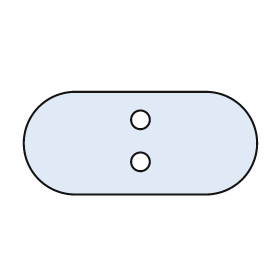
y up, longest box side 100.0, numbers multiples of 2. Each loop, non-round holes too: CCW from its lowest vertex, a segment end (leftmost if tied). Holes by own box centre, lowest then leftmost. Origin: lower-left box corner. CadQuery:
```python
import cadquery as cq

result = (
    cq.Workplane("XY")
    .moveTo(22.0, 0.0)
    .lineTo(78.0, 0.0)
    .threePointArc((100.0, 22.0), (78.0, 44.0))
    .lineTo(22.0, 44.0)
    .threePointArc((0.0, 22.0), (22.0, 0.0))
    .close()
    .moveTo(50.0, 14.0)
    .circle(4.0)
    .moveTo(50.0, 32.0)
    .circle(4.0)
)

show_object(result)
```